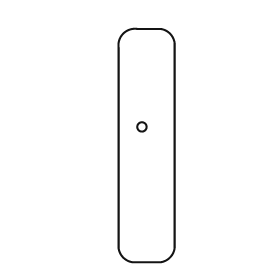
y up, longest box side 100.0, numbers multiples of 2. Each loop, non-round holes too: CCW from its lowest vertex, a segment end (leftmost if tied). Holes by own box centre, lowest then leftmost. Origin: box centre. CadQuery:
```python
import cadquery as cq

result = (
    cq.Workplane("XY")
    .moveTo(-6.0, -50.0)
    .lineTo(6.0, -50.0)
    .threePointArc((10.0, -48.0), (12.0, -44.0))
    .lineTo(12.0, 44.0)
    .threePointArc((10.0, 48.0), (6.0, 50.0))
    .lineTo(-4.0, 50.0)
    .threePointArc((-10.0, 48.0), (-12.0, 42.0))
    .lineTo(-12.0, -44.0)
    .threePointArc((-10.0, -48.0), (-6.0, -50.0))
    .close()
    .moveTo(-2.0, 8.0)
    .circle(2.0)
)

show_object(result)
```